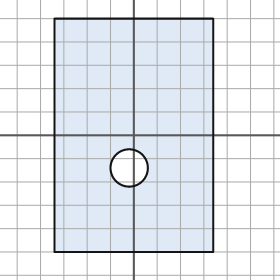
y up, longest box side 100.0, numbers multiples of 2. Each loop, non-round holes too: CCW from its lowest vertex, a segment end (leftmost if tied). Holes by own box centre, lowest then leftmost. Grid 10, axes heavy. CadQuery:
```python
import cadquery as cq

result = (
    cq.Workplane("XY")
    .moveTo(-34.0, -50.0)
    .lineTo(34.0, -50.0)
    .lineTo(34.0, 50.0)
    .lineTo(-34.0, 50.0)
    .close()
    .moveTo(-2.0, -14.0)
    .circle(8.0)
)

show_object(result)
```